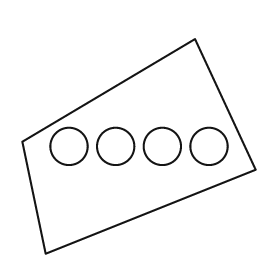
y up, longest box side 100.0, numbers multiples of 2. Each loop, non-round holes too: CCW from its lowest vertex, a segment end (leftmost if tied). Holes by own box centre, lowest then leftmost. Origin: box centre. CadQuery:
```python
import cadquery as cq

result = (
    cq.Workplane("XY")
    .moveTo(-40.0, -46.0)
    .lineTo(50.0, -10.0)
    .lineTo(24.0, 46.0)
    .lineTo(-50.0, 2.0)
    .close()
    .moveTo(-30.0, 0.0)
    .circle(8.0)
    .moveTo(-10.0, 0.0)
    .circle(8.0)
    .moveTo(10.0, 0.0)
    .circle(8.0)
    .moveTo(30.0, 0.0)
    .circle(8.0)
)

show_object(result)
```